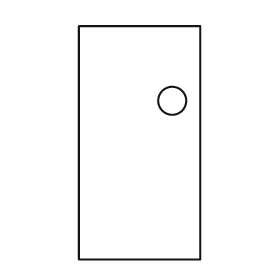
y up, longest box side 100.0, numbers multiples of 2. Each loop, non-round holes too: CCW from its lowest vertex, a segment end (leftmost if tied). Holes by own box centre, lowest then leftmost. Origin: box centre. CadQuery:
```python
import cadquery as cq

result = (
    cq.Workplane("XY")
    .moveTo(-26.0, -50.0)
    .lineTo(26.0, -50.0)
    .lineTo(26.0, 50.0)
    .lineTo(-26.0, 50.0)
    .close()
    .moveTo(14.0, 18.0)
    .circle(6.0)
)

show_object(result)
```